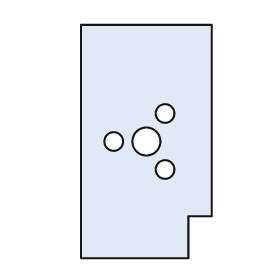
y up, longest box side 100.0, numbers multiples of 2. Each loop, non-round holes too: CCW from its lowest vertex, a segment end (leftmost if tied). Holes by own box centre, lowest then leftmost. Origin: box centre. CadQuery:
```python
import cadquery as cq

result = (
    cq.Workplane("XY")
    .moveTo(-28.0, -50.0)
    .lineTo(18.0, -50.0)
    .lineTo(18.0, -32.0)
    .lineTo(28.0, -32.0)
    .lineTo(28.0, 50.0)
    .lineTo(-28.0, 50.0)
    .close()
    .moveTo(8.0, -12.0)
    .circle(4.0)
    .moveTo(-14.0, 0.0)
    .circle(4.0)
    .moveTo(0.0, 0.0)
    .circle(6.0)
    .moveTo(8.0, 12.0)
    .circle(4.0)
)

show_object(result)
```